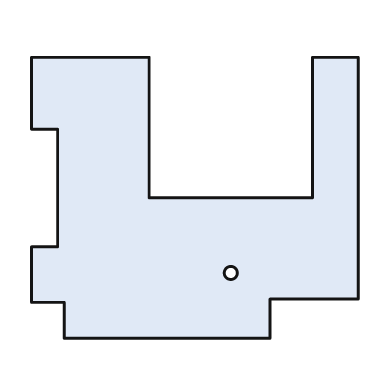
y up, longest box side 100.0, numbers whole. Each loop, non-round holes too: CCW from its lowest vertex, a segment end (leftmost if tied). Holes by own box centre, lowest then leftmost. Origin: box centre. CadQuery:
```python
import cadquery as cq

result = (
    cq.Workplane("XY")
    .moveTo(-40.0, -43.0)
    .lineTo(23.0, -43.0)
    .lineTo(23.0, -31.0)
    .lineTo(50.0, -31.0)
    .lineTo(50.0, 43.0)
    .lineTo(36.0, 43.0)
    .lineTo(36.0, 0.0)
    .lineTo(-14.0, 0.0)
    .lineTo(-14.0, 43.0)
    .lineTo(-50.0, 43.0)
    .lineTo(-50.0, 21.0)
    .lineTo(-42.0, 21.0)
    .lineTo(-42.0, -15.0)
    .lineTo(-50.0, -15.0)
    .lineTo(-50.0, -32.0)
    .lineTo(-40.0, -32.0)
    .close()
    .moveTo(11.0, -23.0)
    .circle(2.0)
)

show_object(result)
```